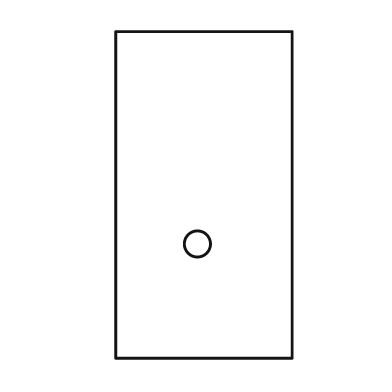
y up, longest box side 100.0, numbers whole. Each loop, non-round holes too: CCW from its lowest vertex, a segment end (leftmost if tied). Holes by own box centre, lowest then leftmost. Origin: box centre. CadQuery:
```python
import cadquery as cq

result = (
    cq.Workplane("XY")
    .moveTo(-27.0, -50.0)
    .lineTo(27.0, -50.0)
    .lineTo(27.0, 50.0)
    .lineTo(-27.0, 50.0)
    .close()
    .moveTo(-2.0, -15.0)
    .circle(4.0)
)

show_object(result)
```